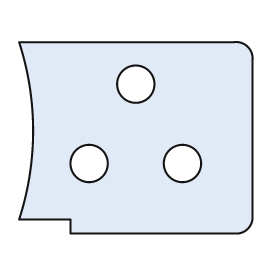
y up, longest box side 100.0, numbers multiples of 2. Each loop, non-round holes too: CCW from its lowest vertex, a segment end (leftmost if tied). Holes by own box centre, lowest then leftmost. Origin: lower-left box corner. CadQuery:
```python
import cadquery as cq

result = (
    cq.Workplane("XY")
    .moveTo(22.0, 0.0)
    .lineTo(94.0, 0.0)
    .threePointArc((98.0, 2.0), (100.0, 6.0))
    .lineTo(100.0, 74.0)
    .threePointArc((98.0, 80.0), (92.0, 82.0))
    .lineTo(0.0, 82.0)
    .threePointArc((6.0, 44.0), (0.0, 6.0))
    .lineTo(22.0, 6.0)
    .close()
    .moveTo(30.0, 30.0)
    .circle(8.0)
    .moveTo(70.0, 30.0)
    .circle(8.0)
    .moveTo(50.0, 64.0)
    .circle(8.0)
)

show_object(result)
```